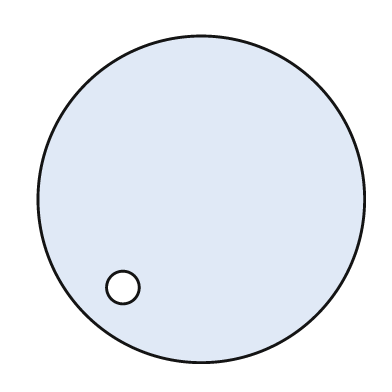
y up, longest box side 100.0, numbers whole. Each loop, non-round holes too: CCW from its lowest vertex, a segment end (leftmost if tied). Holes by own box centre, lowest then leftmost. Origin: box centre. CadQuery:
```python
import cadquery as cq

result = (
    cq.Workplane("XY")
    .moveTo(0.0, 0.0)
    .circle(50.0)
    .moveTo(-24.0, -27.0)
    .circle(5.0)
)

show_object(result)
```